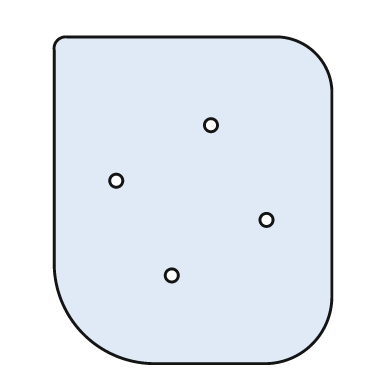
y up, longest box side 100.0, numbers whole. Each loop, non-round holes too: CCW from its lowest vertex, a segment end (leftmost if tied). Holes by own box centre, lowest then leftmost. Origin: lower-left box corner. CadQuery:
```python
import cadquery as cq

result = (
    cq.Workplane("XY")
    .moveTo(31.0, 0.0)
    .lineTo(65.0, 0.0)
    .threePointArc((79.0, 6.0), (85.0, 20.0))
    .lineTo(85.0, 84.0)
    .threePointArc((80.0, 95.0), (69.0, 100.0))
    .lineTo(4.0, 100.0)
    .threePointArc((1.0, 99.0), (0.0, 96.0))
    .lineTo(0.0, 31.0)
    .threePointArc((9.0, 9.0), (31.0, 0.0))
    .close()
    .moveTo(36.0, 27.0)
    .circle(2.0)
    .moveTo(65.0, 44.0)
    .circle(2.0)
    .moveTo(19.0, 56.0)
    .circle(2.0)
    .moveTo(48.0, 73.0)
    .circle(2.0)
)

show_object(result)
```